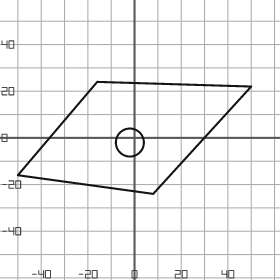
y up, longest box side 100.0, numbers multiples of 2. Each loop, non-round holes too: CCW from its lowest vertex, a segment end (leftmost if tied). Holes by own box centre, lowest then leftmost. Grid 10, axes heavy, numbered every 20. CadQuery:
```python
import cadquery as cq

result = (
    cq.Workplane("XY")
    .moveTo(8.0, -24.0)
    .lineTo(50.0, 22.0)
    .lineTo(-16.0, 24.0)
    .lineTo(-50.0, -16.0)
    .close()
    .moveTo(-2.0, -2.0)
    .circle(6.0)
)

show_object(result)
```